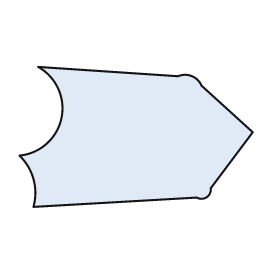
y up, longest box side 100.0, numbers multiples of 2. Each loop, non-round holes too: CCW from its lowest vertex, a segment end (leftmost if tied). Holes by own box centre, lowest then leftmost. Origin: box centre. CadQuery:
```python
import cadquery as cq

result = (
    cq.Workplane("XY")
    .moveTo(-44.0, -30.0)
    .lineTo(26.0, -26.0)
    .threePointArc((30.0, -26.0), (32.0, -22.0))
    .lineTo(50.0, 2.0)
    .lineTo(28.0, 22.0)
    .threePointArc((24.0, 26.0), (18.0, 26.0))
    .lineTo(-42.0, 30.0)
    .threePointArc((-32.0, 8.0), (-50.0, -8.0))
    .threePointArc((-44.0, -18.0), (-44.0, -30.0))
    .close()
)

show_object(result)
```